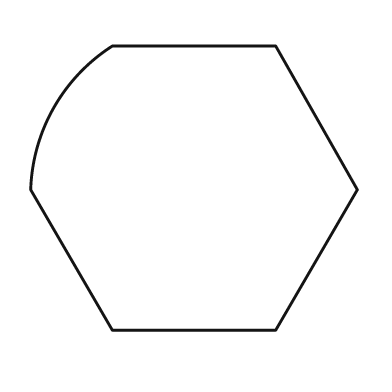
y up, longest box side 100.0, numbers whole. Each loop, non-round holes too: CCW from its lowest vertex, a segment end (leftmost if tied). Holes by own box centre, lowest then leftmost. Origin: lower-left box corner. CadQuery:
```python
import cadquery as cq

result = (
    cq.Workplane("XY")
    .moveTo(25.0, 0.0)
    .lineTo(75.0, 0.0)
    .lineTo(100.0, 43.0)
    .lineTo(75.0, 87.0)
    .lineTo(25.0, 87.0)
    .threePointArc((7.0, 68.0), (0.0, 43.0))
    .close()
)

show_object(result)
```